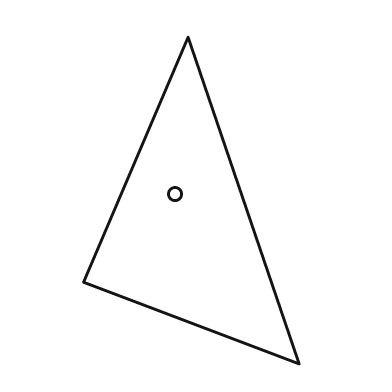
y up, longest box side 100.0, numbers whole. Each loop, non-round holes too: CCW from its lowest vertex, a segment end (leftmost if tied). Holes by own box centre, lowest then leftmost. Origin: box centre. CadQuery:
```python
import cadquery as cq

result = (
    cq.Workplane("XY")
    .moveTo(33.0, -50.0)
    .lineTo(-1.0, 50.0)
    .lineTo(-33.0, -25.0)
    .close()
    .moveTo(-5.0, 2.0)
    .circle(2.0)
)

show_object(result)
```